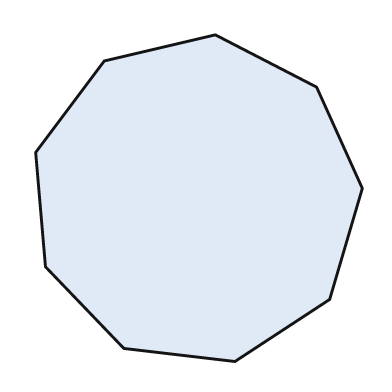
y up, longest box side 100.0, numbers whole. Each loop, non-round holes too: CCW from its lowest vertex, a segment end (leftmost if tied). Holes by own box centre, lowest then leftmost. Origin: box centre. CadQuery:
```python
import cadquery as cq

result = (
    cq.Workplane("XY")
    .moveTo(11.0, -50.0)
    .lineTo(40.0, -31.0)
    .lineTo(50.0, 3.0)
    .lineTo(36.0, 34.0)
    .lineTo(5.0, 50.0)
    .lineTo(-29.0, 42.0)
    .lineTo(-50.0, 14.0)
    .lineTo(-47.0, -21.0)
    .lineTo(-23.0, -46.0)
    .close()
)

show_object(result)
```